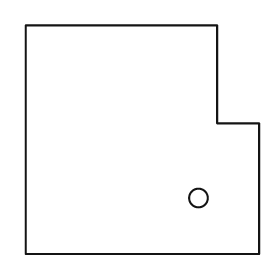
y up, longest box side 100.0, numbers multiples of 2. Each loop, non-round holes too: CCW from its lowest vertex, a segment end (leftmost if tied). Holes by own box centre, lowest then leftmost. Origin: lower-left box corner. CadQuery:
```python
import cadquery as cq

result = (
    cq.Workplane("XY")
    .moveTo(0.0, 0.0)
    .lineTo(100.0, 0.0)
    .lineTo(100.0, 56.0)
    .lineTo(82.0, 56.0)
    .lineTo(82.0, 98.0)
    .lineTo(0.0, 98.0)
    .close()
    .moveTo(74.0, 24.0)
    .circle(4.0)
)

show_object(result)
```